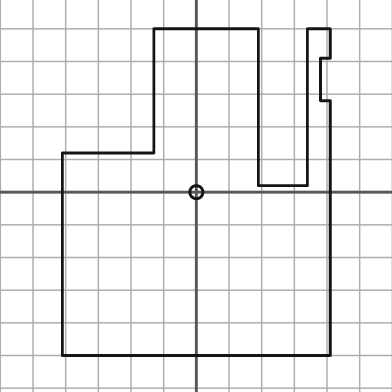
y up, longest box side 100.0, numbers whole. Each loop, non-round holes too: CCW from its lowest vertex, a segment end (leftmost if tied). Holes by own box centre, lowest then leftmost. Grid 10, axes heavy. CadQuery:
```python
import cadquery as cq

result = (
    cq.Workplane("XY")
    .moveTo(-41.0, -50.0)
    .lineTo(41.0, -50.0)
    .lineTo(41.0, 28.0)
    .lineTo(38.0, 28.0)
    .lineTo(38.0, 41.0)
    .lineTo(41.0, 41.0)
    .lineTo(41.0, 50.0)
    .lineTo(34.0, 50.0)
    .lineTo(34.0, 2.0)
    .lineTo(19.0, 2.0)
    .lineTo(19.0, 50.0)
    .lineTo(-13.0, 50.0)
    .lineTo(-13.0, 12.0)
    .lineTo(-41.0, 12.0)
    .close()
    .moveTo(0.0, 0.0)
    .circle(2.0)
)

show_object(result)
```